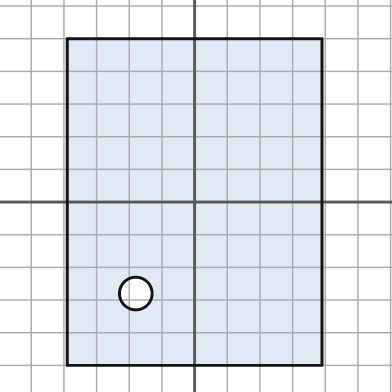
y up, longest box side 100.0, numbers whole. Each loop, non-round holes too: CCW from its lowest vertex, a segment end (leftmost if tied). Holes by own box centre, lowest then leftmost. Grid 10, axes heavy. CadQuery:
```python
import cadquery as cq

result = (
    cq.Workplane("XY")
    .moveTo(-39.0, -50.0)
    .lineTo(39.0, -50.0)
    .lineTo(39.0, 50.0)
    .lineTo(-39.0, 50.0)
    .close()
    .moveTo(-18.0, -28.0)
    .circle(5.0)
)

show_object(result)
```